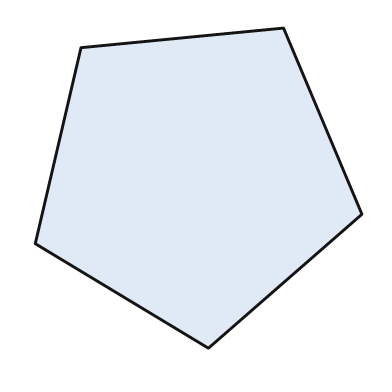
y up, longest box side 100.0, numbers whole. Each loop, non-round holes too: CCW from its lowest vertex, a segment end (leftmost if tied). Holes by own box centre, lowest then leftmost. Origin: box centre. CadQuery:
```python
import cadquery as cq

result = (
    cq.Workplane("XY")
    .moveTo(3.0, -49.0)
    .lineTo(50.0, -8.0)
    .lineTo(26.0, 49.0)
    .lineTo(-36.0, 43.0)
    .lineTo(-50.0, -17.0)
    .close()
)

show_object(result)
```